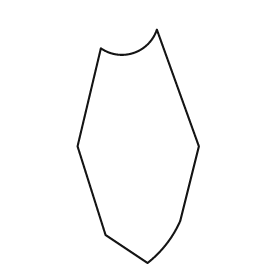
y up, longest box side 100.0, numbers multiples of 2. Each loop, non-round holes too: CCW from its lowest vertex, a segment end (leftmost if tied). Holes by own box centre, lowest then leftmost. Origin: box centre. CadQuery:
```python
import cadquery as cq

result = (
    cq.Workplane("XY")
    .moveTo(4.0, -50.0)
    .threePointArc((12.0, -42.0), (18.0, -32.0))
    .lineTo(26.0, 0.0)
    .lineTo(8.0, 50.0)
    .threePointArc((-2.0, 40.0), (-16.0, 42.0))
    .lineTo(-26.0, 0.0)
    .lineTo(-14.0, -38.0)
    .close()
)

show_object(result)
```